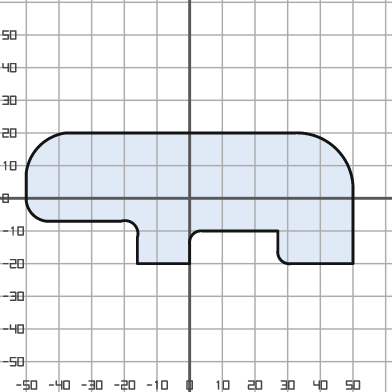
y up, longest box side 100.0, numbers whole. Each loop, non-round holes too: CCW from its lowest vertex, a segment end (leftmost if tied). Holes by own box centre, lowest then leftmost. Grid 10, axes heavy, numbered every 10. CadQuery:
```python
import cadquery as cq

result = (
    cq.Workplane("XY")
    .moveTo(-16.0, -20.0)
    .lineTo(0.0, -20.0)
    .lineTo(0.0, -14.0)
    .threePointArc((1.0, -11.0), (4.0, -10.0))
    .lineTo(27.0, -10.0)
    .lineTo(27.0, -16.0)
    .threePointArc((28.0, -19.0), (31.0, -20.0))
    .lineTo(50.0, -20.0)
    .lineTo(50.0, 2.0)
    .threePointArc((45.0, 15.0), (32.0, 20.0))
    .lineTo(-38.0, 20.0)
    .threePointArc((-46.0, 16.0), (-50.0, 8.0))
    .lineTo(-50.0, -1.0)
    .threePointArc((-48.0, -5.0), (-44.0, -7.0))
    .lineTo(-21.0, -7.0)
    .threePointArc((-17.0, -8.0), (-16.0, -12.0))
    .close()
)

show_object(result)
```